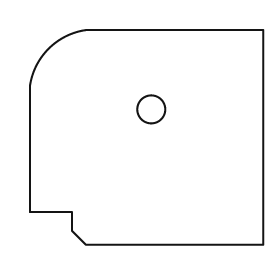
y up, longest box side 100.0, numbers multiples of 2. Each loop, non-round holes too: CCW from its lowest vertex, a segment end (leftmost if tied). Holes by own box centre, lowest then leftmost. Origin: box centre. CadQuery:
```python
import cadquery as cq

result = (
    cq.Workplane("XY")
    .moveTo(-26.0, -46.0)
    .lineTo(50.0, -46.0)
    .lineTo(50.0, 46.0)
    .lineTo(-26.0, 46.0)
    .threePointArc((-42.0, 38.0), (-50.0, 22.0))
    .lineTo(-50.0, -32.0)
    .lineTo(-32.0, -32.0)
    .lineTo(-32.0, -40.0)
    .close()
    .moveTo(2.0, 12.0)
    .circle(6.0)
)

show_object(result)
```